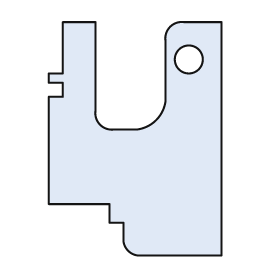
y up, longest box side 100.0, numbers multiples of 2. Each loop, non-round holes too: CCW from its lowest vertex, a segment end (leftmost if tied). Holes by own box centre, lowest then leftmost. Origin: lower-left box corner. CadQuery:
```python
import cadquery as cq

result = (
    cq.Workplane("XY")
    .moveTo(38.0, 0.0)
    .lineTo(74.0, 0.0)
    .lineTo(74.0, 100.0)
    .lineTo(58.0, 100.0)
    .threePointArc((52.0, 98.0), (50.0, 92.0))
    .lineTo(50.0, 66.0)
    .threePointArc((46.0, 58.0), (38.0, 54.0))
    .lineTo(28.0, 54.0)
    .threePointArc((22.0, 56.0), (20.0, 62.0))
    .lineTo(20.0, 100.0)
    .lineTo(6.0, 100.0)
    .lineTo(6.0, 78.0)
    .lineTo(0.0, 78.0)
    .lineTo(0.0, 74.0)
    .lineTo(6.0, 74.0)
    .lineTo(6.0, 68.0)
    .lineTo(0.0, 68.0)
    .lineTo(0.0, 22.0)
    .lineTo(26.0, 22.0)
    .lineTo(26.0, 14.0)
    .lineTo(32.0, 14.0)
    .lineTo(32.0, 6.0)
    .threePointArc((34.0, 2.0), (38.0, 0.0))
    .close()
    .moveTo(60.0, 84.0)
    .circle(6.0)
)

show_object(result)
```